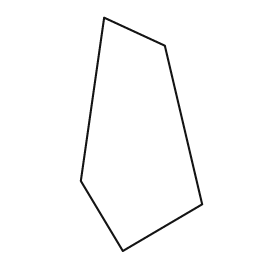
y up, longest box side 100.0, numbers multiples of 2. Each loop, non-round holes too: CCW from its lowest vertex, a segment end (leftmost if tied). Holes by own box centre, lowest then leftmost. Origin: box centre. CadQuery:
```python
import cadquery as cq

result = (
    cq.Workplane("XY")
    .moveTo(-8.0, -50.0)
    .lineTo(26.0, -30.0)
    .lineTo(10.0, 38.0)
    .lineTo(-16.0, 50.0)
    .lineTo(-26.0, -20.0)
    .close()
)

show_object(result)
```